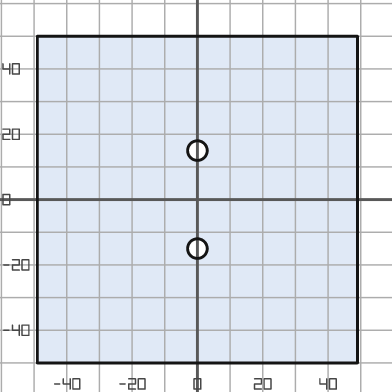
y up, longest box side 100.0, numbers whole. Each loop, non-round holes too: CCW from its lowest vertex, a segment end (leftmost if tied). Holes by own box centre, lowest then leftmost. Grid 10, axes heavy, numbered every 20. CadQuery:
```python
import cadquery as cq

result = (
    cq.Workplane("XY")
    .moveTo(-49.0, -50.0)
    .lineTo(49.0, -50.0)
    .lineTo(49.0, 50.0)
    .lineTo(-49.0, 50.0)
    .close()
    .moveTo(0.0, -15.0)
    .circle(3.0)
    .moveTo(0.0, 15.0)
    .circle(3.0)
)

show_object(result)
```